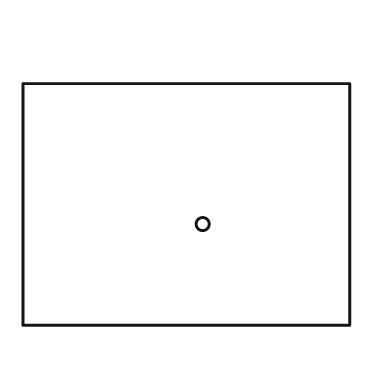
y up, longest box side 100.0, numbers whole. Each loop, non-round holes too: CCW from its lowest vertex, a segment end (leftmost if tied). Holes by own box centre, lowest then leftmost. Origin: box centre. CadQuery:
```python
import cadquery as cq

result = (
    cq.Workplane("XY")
    .moveTo(-50.0, -37.0)
    .lineTo(50.0, -37.0)
    .lineTo(50.0, 37.0)
    .lineTo(-50.0, 37.0)
    .close()
    .moveTo(5.0, -6.0)
    .circle(2.0)
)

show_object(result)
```